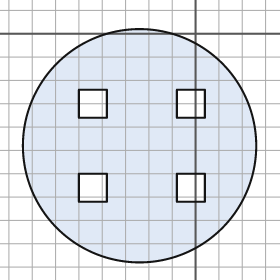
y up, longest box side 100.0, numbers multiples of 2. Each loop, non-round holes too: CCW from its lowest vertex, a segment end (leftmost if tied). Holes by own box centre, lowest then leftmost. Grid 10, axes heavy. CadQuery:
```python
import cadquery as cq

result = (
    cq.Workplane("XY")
    .moveTo(-24.0, -48.0)
    .circle(50.0)
    .moveTo(-50.0, -72.0)
    .lineTo(-38.0, -72.0)
    .lineTo(-38.0, -60.0)
    .lineTo(-50.0, -60.0)
    .close()
    .moveTo(-8.0, -72.0)
    .lineTo(4.0, -72.0)
    .lineTo(4.0, -60.0)
    .lineTo(-8.0, -60.0)
    .close()
    .moveTo(-50.0, -36.0)
    .lineTo(-38.0, -36.0)
    .lineTo(-38.0, -24.0)
    .lineTo(-50.0, -24.0)
    .close()
    .moveTo(-8.0, -36.0)
    .lineTo(4.0, -36.0)
    .lineTo(4.0, -24.0)
    .lineTo(-8.0, -24.0)
    .close()
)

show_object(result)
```